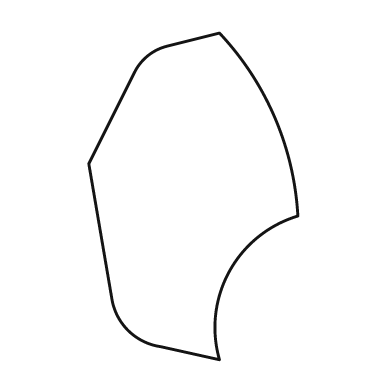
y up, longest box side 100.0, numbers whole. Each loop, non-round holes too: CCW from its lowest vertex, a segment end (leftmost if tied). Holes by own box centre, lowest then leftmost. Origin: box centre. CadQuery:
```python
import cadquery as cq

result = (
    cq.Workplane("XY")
    .moveTo(8.0, -50.0)
    .threePointArc((11.0, -23.0), (32.0, -6.0))
    .threePointArc((25.0, 24.0), (8.0, 50.0))
    .lineTo(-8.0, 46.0)
    .threePointArc((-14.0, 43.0), (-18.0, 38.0))
    .lineTo(-32.0, 10.0)
    .lineTo(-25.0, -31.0)
    .threePointArc((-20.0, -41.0), (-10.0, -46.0))
    .close()
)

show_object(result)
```